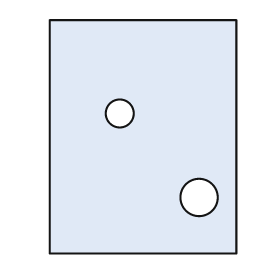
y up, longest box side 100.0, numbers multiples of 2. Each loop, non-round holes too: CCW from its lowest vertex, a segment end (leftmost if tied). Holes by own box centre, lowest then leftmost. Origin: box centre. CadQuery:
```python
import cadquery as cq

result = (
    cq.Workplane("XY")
    .moveTo(-40.0, -50.0)
    .lineTo(40.0, -50.0)
    .lineTo(40.0, 50.0)
    .lineTo(-40.0, 50.0)
    .close()
    .moveTo(24.0, -26.0)
    .circle(8.0)
    .moveTo(-10.0, 10.0)
    .circle(6.0)
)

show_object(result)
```